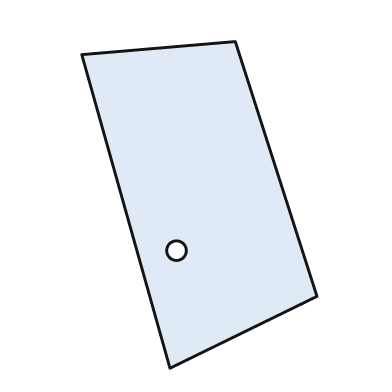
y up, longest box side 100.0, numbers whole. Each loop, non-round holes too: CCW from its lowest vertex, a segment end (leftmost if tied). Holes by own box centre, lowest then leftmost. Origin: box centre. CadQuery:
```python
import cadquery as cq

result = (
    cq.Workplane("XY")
    .moveTo(-9.0, -50.0)
    .lineTo(36.0, -28.0)
    .lineTo(11.0, 50.0)
    .lineTo(-36.0, 46.0)
    .close()
    .moveTo(-7.0, -14.0)
    .circle(3.0)
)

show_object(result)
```